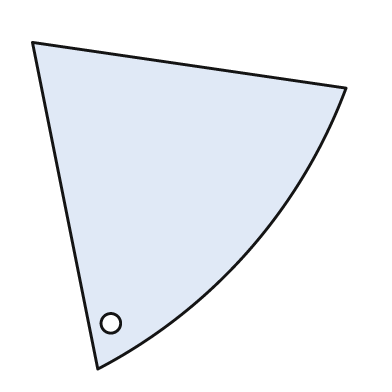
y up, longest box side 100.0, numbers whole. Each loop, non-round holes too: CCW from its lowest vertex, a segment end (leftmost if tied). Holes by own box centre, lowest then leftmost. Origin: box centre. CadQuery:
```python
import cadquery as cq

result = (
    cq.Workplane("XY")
    .moveTo(-28.0, -50.0)
    .threePointArc((18.0, -14.0), (48.0, 36.0))
    .lineTo(-48.0, 50.0)
    .close()
    .moveTo(-24.0, -36.0)
    .circle(3.0)
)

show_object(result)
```